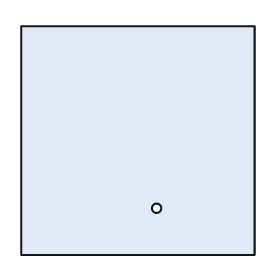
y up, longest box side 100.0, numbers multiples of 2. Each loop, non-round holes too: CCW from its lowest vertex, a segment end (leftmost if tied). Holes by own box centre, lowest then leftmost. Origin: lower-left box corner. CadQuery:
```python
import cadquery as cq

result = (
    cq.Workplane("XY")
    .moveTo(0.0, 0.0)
    .lineTo(100.0, 0.0)
    .lineTo(100.0, 98.0)
    .lineTo(0.0, 98.0)
    .close()
    .moveTo(58.0, 20.0)
    .circle(2.0)
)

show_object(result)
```